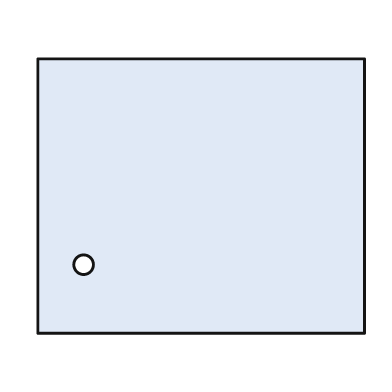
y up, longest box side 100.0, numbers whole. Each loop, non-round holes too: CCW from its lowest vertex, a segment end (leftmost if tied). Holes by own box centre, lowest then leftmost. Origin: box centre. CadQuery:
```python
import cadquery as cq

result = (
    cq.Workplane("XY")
    .moveTo(-50.0, -42.0)
    .lineTo(50.0, -42.0)
    .lineTo(50.0, 42.0)
    .lineTo(-50.0, 42.0)
    .close()
    .moveTo(-36.0, -21.0)
    .circle(3.0)
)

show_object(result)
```